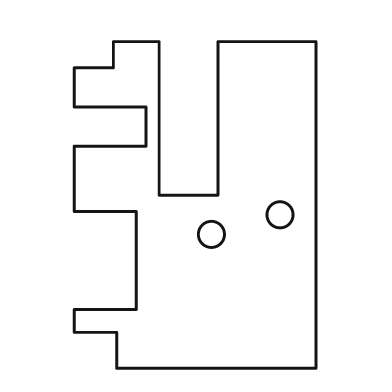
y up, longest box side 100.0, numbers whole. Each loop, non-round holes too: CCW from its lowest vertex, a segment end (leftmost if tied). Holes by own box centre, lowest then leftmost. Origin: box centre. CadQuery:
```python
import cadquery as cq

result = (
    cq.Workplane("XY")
    .moveTo(-24.0, -50.0)
    .lineTo(37.0, -50.0)
    .lineTo(37.0, 50.0)
    .lineTo(7.0, 50.0)
    .lineTo(7.0, 3.0)
    .lineTo(-11.0, 3.0)
    .lineTo(-11.0, 50.0)
    .lineTo(-25.0, 50.0)
    .lineTo(-25.0, 42.0)
    .lineTo(-37.0, 42.0)
    .lineTo(-37.0, 30.0)
    .lineTo(-15.0, 30.0)
    .lineTo(-15.0, 18.0)
    .lineTo(-37.0, 18.0)
    .lineTo(-37.0, -2.0)
    .lineTo(-18.0, -2.0)
    .lineTo(-18.0, -32.0)
    .lineTo(-37.0, -32.0)
    .lineTo(-37.0, -39.0)
    .lineTo(-24.0, -39.0)
    .close()
    .moveTo(5.0, -9.0)
    .circle(4.0)
    .moveTo(26.0, -3.0)
    .circle(4.0)
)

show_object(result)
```